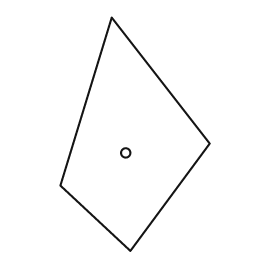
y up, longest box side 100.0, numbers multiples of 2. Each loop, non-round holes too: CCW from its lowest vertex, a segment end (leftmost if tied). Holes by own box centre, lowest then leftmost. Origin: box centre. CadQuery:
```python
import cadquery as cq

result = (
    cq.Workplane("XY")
    .moveTo(-2.0, -50.0)
    .lineTo(32.0, -4.0)
    .lineTo(-10.0, 50.0)
    .lineTo(-32.0, -22.0)
    .close()
    .moveTo(-4.0, -8.0)
    .circle(2.0)
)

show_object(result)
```